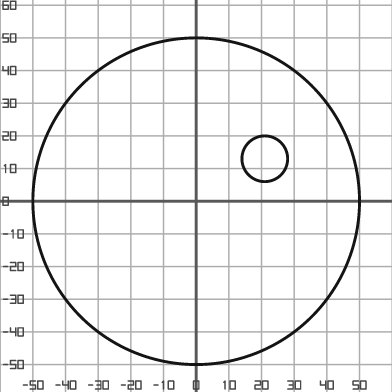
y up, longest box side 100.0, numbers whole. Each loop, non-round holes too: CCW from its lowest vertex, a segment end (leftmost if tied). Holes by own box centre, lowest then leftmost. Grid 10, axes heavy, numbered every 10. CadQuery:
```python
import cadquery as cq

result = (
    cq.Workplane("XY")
    .moveTo(0.0, 0.0)
    .circle(50.0)
    .moveTo(21.0, 13.0)
    .circle(7.0)
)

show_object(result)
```